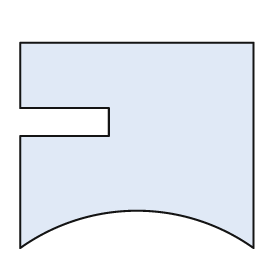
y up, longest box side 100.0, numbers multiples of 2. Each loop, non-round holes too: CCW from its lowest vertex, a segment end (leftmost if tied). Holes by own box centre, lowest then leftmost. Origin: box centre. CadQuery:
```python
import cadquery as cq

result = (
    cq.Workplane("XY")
    .moveTo(-50.0, -44.0)
    .threePointArc((0.0, -28.0), (50.0, -44.0))
    .lineTo(50.0, 44.0)
    .lineTo(-50.0, 44.0)
    .lineTo(-50.0, 16.0)
    .lineTo(-12.0, 16.0)
    .lineTo(-12.0, 4.0)
    .lineTo(-50.0, 4.0)
    .close()
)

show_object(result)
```